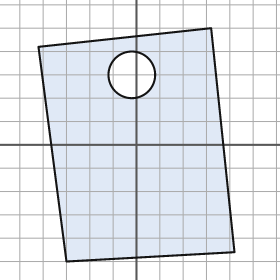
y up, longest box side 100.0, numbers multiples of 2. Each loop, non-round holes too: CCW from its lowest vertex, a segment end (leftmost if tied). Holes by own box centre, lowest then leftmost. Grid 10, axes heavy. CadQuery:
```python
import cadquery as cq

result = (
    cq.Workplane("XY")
    .moveTo(-30.0, -50.0)
    .lineTo(42.0, -46.0)
    .lineTo(32.0, 50.0)
    .lineTo(-42.0, 42.0)
    .close()
    .moveTo(-2.0, 30.0)
    .circle(10.0)
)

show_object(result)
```